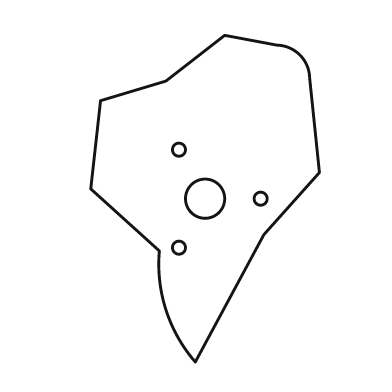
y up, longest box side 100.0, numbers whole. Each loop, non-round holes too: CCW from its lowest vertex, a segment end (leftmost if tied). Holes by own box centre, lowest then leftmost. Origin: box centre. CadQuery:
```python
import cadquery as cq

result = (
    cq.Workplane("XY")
    .moveTo(-3.0, -50.0)
    .lineTo(18.0, -11.0)
    .lineTo(35.0, 8.0)
    .lineTo(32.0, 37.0)
    .threePointArc((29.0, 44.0), (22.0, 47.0))
    .lineTo(6.0, 50.0)
    .lineTo(-12.0, 36.0)
    .lineTo(-32.0, 30.0)
    .lineTo(-35.0, 3.0)
    .lineTo(-14.0, -16.0)
    .threePointArc((-12.0, -34.0), (-3.0, -50.0))
    .close()
    .moveTo(-8.0, -15.0)
    .circle(2.0)
    .moveTo(0.0, 0.0)
    .circle(6.0)
    .moveTo(17.0, 0.0)
    .circle(2.0)
    .moveTo(-8.0, 15.0)
    .circle(2.0)
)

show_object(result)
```